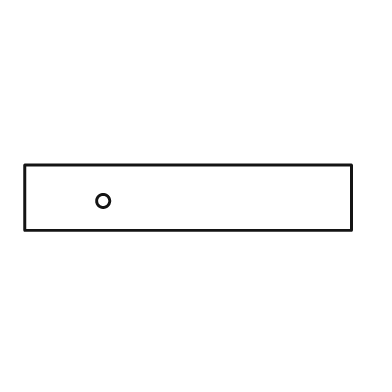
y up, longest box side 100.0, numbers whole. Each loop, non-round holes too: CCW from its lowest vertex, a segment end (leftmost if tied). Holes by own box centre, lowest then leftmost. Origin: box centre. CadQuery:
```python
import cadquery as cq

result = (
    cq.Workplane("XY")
    .moveTo(-50.0, -10.0)
    .lineTo(50.0, -10.0)
    .lineTo(50.0, 10.0)
    .lineTo(-50.0, 10.0)
    .close()
    .moveTo(-26.0, -1.0)
    .circle(2.0)
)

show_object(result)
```